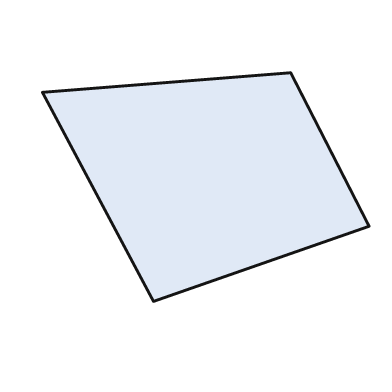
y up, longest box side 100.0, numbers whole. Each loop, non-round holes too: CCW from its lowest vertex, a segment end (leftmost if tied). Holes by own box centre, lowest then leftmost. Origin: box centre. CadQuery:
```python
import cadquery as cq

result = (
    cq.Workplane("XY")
    .moveTo(-16.0, -35.0)
    .lineTo(50.0, -12.0)
    .lineTo(26.0, 35.0)
    .lineTo(-50.0, 29.0)
    .close()
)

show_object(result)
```